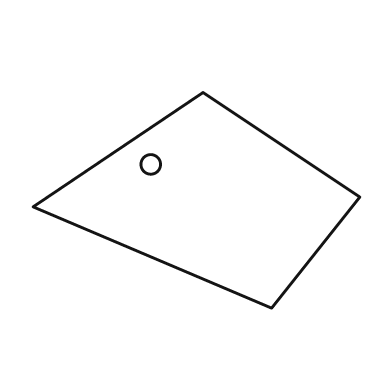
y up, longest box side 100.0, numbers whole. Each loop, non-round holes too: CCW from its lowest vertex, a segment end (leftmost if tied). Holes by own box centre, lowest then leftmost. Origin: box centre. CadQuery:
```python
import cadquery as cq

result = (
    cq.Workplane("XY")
    .moveTo(23.0, -33.0)
    .lineTo(50.0, 1.0)
    .lineTo(2.0, 33.0)
    .lineTo(-50.0, -2.0)
    .close()
    .moveTo(-14.0, 11.0)
    .circle(3.0)
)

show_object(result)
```